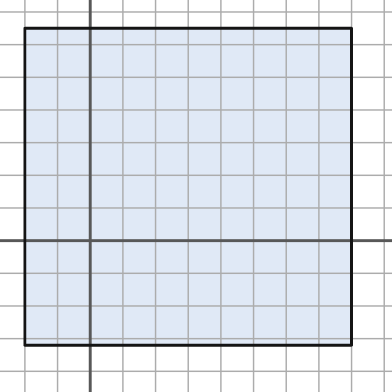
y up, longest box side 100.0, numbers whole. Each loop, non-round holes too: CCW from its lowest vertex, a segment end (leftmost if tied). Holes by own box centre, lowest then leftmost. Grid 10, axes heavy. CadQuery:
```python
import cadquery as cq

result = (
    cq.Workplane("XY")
    .moveTo(-20.0, -32.0)
    .lineTo(80.0, -32.0)
    .lineTo(80.0, 65.0)
    .lineTo(-20.0, 65.0)
    .close()
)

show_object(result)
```